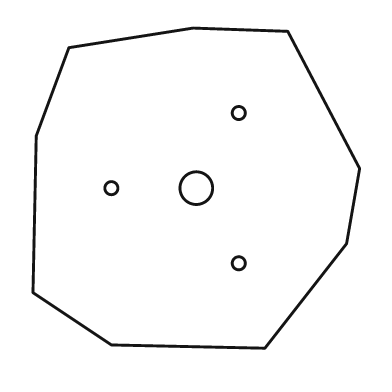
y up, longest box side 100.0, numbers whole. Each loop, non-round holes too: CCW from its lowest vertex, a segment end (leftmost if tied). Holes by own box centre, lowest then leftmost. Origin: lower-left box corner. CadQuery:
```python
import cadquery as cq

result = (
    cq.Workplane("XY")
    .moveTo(71.0, 0.0)
    .lineTo(96.0, 32.0)
    .lineTo(100.0, 55.0)
    .lineTo(78.0, 97.0)
    .lineTo(49.0, 98.0)
    .lineTo(11.0, 92.0)
    .lineTo(1.0, 65.0)
    .lineTo(0.0, 17.0)
    .lineTo(24.0, 1.0)
    .close()
    .moveTo(63.0, 26.0)
    .circle(2.0)
    .moveTo(24.0, 49.0)
    .circle(2.0)
    .moveTo(50.0, 49.0)
    .circle(5.0)
    .moveTo(63.0, 72.0)
    .circle(2.0)
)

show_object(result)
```